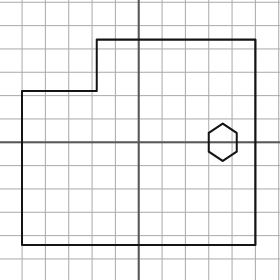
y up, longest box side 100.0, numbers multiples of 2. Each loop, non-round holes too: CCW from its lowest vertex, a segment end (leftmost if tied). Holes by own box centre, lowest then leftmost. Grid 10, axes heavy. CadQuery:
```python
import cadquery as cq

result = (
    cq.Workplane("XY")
    .moveTo(-50.0, -44.0)
    .lineTo(50.0, -44.0)
    .lineTo(50.0, 44.0)
    .lineTo(-18.0, 44.0)
    .lineTo(-18.0, 22.0)
    .lineTo(-50.0, 22.0)
    .close()
    .moveTo(36.0, -8.0)
    .lineTo(42.0, -4.0)
    .lineTo(42.0, 4.0)
    .lineTo(36.0, 8.0)
    .lineTo(30.0, 4.0)
    .lineTo(30.0, -4.0)
    .close()
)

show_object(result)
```